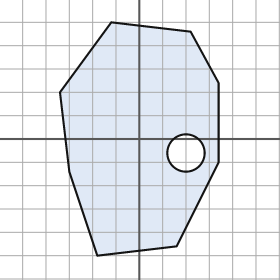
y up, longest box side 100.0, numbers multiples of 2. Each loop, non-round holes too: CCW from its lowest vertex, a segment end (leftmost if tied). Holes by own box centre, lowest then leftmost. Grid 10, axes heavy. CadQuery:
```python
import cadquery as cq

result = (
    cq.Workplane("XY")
    .moveTo(-18.0, -50.0)
    .lineTo(16.0, -46.0)
    .lineTo(34.0, -10.0)
    .lineTo(34.0, 24.0)
    .lineTo(22.0, 46.0)
    .lineTo(-12.0, 50.0)
    .lineTo(-34.0, 20.0)
    .lineTo(-30.0, -14.0)
    .close()
    .moveTo(20.0, -6.0)
    .circle(8.0)
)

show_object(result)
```